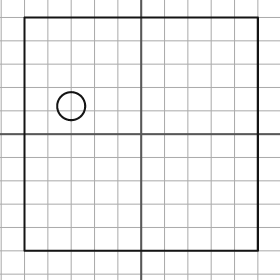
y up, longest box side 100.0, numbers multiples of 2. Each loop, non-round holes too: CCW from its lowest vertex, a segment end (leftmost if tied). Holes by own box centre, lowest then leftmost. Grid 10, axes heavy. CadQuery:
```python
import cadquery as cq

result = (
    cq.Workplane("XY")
    .moveTo(-50.0, -50.0)
    .lineTo(50.0, -50.0)
    .lineTo(50.0, 50.0)
    .lineTo(-50.0, 50.0)
    .close()
    .moveTo(-30.0, 12.0)
    .circle(6.0)
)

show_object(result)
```